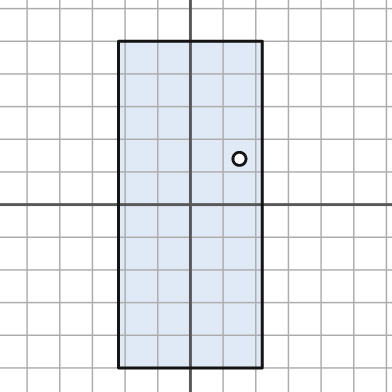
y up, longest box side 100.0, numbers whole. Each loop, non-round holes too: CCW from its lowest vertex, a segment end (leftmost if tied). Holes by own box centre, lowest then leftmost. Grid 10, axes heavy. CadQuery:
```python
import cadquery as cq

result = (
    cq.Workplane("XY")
    .moveTo(-22.0, -50.0)
    .lineTo(22.0, -50.0)
    .lineTo(22.0, 50.0)
    .lineTo(-22.0, 50.0)
    .close()
    .moveTo(15.0, 14.0)
    .circle(2.0)
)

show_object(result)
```